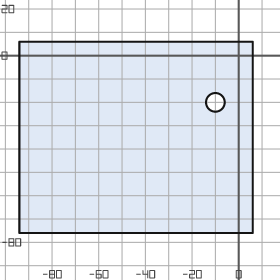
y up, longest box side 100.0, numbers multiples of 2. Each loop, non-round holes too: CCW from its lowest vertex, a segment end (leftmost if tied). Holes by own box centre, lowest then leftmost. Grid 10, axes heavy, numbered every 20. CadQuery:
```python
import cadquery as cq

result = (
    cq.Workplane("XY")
    .moveTo(-94.0, -76.0)
    .lineTo(6.0, -76.0)
    .lineTo(6.0, 6.0)
    .lineTo(-94.0, 6.0)
    .close()
    .moveTo(-10.0, -20.0)
    .circle(4.0)
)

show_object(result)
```